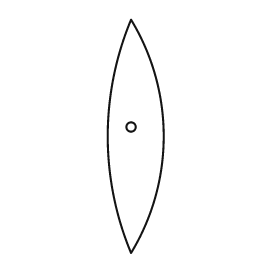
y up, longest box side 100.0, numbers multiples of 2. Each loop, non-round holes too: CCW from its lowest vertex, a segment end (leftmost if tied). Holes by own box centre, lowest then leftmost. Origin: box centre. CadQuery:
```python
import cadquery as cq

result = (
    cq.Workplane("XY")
    .moveTo(-2.0, -50.0)
    .threePointArc((12.0, 0.0), (-2.0, 50.0))
    .threePointArc((-12.0, 0.0), (-2.0, -50.0))
    .close()
    .moveTo(-2.0, 4.0)
    .circle(2.0)
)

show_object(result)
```